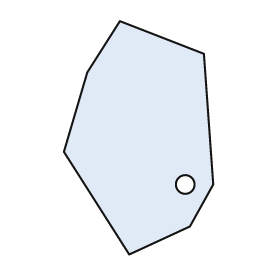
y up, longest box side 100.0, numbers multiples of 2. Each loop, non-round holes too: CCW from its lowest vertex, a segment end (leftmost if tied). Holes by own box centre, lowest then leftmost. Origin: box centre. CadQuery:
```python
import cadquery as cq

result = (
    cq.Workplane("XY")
    .moveTo(-4.0, -50.0)
    .lineTo(22.0, -38.0)
    .lineTo(32.0, -20.0)
    .lineTo(28.0, 36.0)
    .lineTo(-8.0, 50.0)
    .lineTo(-22.0, 28.0)
    .lineTo(-32.0, -6.0)
    .close()
    .moveTo(20.0, -20.0)
    .circle(4.0)
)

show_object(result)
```